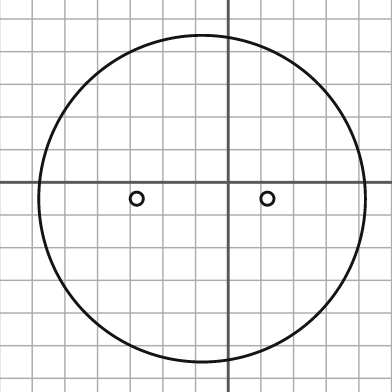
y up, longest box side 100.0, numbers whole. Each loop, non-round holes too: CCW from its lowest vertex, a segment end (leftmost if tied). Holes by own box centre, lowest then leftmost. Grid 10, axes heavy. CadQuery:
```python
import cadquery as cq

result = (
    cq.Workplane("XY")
    .moveTo(-8.0, -5.0)
    .circle(50.0)
    .moveTo(-28.0, -5.0)
    .circle(2.0)
    .moveTo(12.0, -5.0)
    .circle(2.0)
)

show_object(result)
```